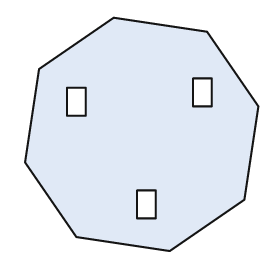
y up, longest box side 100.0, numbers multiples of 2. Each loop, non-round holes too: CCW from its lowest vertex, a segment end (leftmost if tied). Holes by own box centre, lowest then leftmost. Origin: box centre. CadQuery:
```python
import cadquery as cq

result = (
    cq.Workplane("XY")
    .moveTo(12.0, -50.0)
    .lineTo(44.0, -28.0)
    .lineTo(50.0, 12.0)
    .lineTo(28.0, 44.0)
    .lineTo(-12.0, 50.0)
    .lineTo(-44.0, 28.0)
    .lineTo(-50.0, -12.0)
    .lineTo(-28.0, -44.0)
    .close()
    .moveTo(-2.0, -36.0)
    .lineTo(6.0, -36.0)
    .lineTo(6.0, -24.0)
    .lineTo(-2.0, -24.0)
    .close()
    .moveTo(-32.0, 8.0)
    .lineTo(-24.0, 8.0)
    .lineTo(-24.0, 20.0)
    .lineTo(-32.0, 20.0)
    .close()
    .moveTo(22.0, 12.0)
    .lineTo(30.0, 12.0)
    .lineTo(30.0, 24.0)
    .lineTo(22.0, 24.0)
    .close()
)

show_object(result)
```